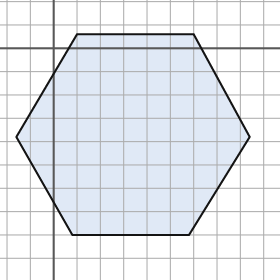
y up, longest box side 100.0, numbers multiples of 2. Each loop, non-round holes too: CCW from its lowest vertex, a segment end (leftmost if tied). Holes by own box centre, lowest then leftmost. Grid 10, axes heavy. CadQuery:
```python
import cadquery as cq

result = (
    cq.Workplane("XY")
    .moveTo(8.0, -80.0)
    .lineTo(58.0, -80.0)
    .lineTo(84.0, -38.0)
    .lineTo(60.0, 6.0)
    .lineTo(10.0, 6.0)
    .lineTo(-16.0, -38.0)
    .close()
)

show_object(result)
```